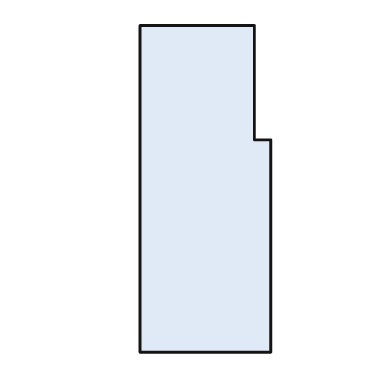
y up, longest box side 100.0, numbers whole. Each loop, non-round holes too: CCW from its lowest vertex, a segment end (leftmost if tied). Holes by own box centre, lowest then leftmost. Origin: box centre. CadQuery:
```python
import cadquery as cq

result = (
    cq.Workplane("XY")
    .moveTo(-20.0, -50.0)
    .lineTo(20.0, -50.0)
    .lineTo(20.0, 15.0)
    .lineTo(15.0, 15.0)
    .lineTo(15.0, 50.0)
    .lineTo(-20.0, 50.0)
    .close()
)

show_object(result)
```